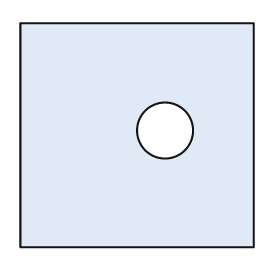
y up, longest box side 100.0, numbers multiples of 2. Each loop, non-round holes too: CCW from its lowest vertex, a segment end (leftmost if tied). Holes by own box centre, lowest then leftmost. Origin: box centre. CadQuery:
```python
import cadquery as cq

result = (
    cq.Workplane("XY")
    .moveTo(-50.0, -48.0)
    .lineTo(50.0, -48.0)
    .lineTo(50.0, 48.0)
    .lineTo(-50.0, 48.0)
    .close()
    .moveTo(12.0, 2.0)
    .circle(12.0)
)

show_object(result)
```